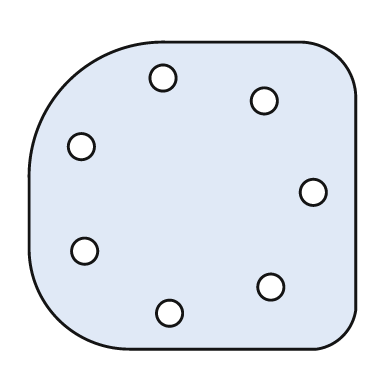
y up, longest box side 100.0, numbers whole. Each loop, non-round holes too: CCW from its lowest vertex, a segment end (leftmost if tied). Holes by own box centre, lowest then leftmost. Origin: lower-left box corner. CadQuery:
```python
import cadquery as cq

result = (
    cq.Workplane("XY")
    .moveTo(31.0, 0.0)
    .lineTo(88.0, 0.0)
    .threePointArc((96.0, 4.0), (100.0, 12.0))
    .lineTo(100.0, 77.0)
    .threePointArc((95.0, 89.0), (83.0, 94.0))
    .lineTo(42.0, 94.0)
    .threePointArc((12.0, 82.0), (0.0, 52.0))
    .lineTo(0.0, 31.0)
    .threePointArc((9.0, 9.0), (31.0, 0.0))
    .close()
    .moveTo(43.0, 11.0)
    .circle(4.0)
    .moveTo(74.0, 19.0)
    .circle(4.0)
    .moveTo(17.0, 30.0)
    .circle(4.0)
    .moveTo(87.0, 48.0)
    .circle(4.0)
    .moveTo(16.0, 62.0)
    .circle(4.0)
    .moveTo(72.0, 76.0)
    .circle(4.0)
    .moveTo(41.0, 83.0)
    .circle(4.0)
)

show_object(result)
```